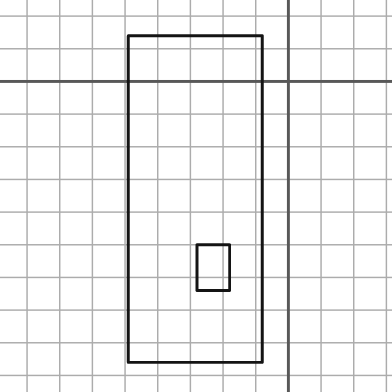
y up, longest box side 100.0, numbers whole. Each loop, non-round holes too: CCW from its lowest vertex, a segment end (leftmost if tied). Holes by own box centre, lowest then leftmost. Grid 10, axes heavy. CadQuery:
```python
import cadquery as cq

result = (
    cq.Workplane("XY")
    .moveTo(-49.0, -86.0)
    .lineTo(-8.0, -86.0)
    .lineTo(-8.0, 14.0)
    .lineTo(-49.0, 14.0)
    .close()
    .moveTo(-28.0, -64.0)
    .lineTo(-18.0, -64.0)
    .lineTo(-18.0, -50.0)
    .lineTo(-28.0, -50.0)
    .close()
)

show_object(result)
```